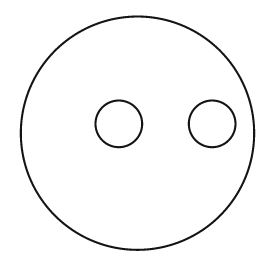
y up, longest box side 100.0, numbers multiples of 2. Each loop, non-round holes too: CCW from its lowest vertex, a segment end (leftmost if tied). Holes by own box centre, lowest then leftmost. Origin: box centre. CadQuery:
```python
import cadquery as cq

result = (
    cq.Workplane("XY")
    .moveTo(0.0, 0.0)
    .circle(50.0)
    .moveTo(-8.0, 4.0)
    .circle(10.0)
    .moveTo(32.0, 4.0)
    .circle(10.0)
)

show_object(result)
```